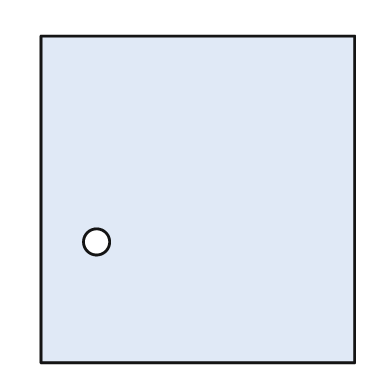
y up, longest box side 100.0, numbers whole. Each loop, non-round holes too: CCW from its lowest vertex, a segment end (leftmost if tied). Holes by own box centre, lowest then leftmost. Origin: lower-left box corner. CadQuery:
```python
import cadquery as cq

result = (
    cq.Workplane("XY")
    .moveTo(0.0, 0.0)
    .lineTo(96.0, 0.0)
    .lineTo(96.0, 100.0)
    .lineTo(0.0, 100.0)
    .close()
    .moveTo(17.0, 37.0)
    .circle(4.0)
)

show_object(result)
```